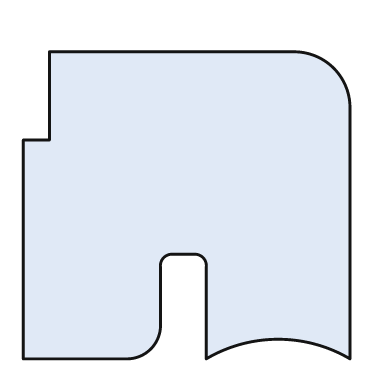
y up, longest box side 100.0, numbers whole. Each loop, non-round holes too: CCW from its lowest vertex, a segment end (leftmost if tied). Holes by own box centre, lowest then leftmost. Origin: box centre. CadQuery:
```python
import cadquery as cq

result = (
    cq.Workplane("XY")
    .moveTo(-50.0, -47.0)
    .lineTo(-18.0, -47.0)
    .threePointArc((-11.0, -44.0), (-8.0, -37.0))
    .lineTo(-8.0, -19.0)
    .threePointArc((-7.0, -16.0), (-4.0, -15.0))
    .lineTo(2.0, -15.0)
    .threePointArc((5.0, -16.0), (6.0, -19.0))
    .lineTo(6.0, -47.0)
    .threePointArc((28.0, -41.0), (50.0, -47.0))
    .lineTo(50.0, 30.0)
    .threePointArc((45.0, 42.0), (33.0, 47.0))
    .lineTo(-42.0, 47.0)
    .lineTo(-42.0, 20.0)
    .lineTo(-50.0, 20.0)
    .close()
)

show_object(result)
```